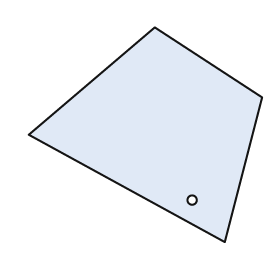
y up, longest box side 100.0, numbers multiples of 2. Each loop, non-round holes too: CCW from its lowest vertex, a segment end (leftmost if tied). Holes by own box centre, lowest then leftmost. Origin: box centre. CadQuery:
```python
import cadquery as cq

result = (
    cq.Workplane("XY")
    .moveTo(34.0, -46.0)
    .lineTo(50.0, 16.0)
    .lineTo(4.0, 46.0)
    .lineTo(-50.0, 0.0)
    .close()
    .moveTo(20.0, -28.0)
    .circle(2.0)
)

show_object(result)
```